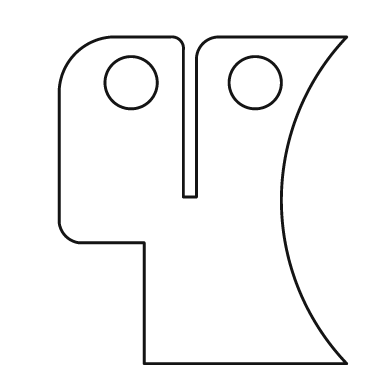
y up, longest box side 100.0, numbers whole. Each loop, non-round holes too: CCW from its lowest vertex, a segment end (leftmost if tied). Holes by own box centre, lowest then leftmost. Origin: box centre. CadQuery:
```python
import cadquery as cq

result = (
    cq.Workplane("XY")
    .moveTo(-18.0, -50.0)
    .lineTo(44.0, -50.0)
    .threePointArc((24.0, 0.0), (44.0, 50.0))
    .lineTo(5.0, 50.0)
    .threePointArc((0.0, 48.0), (-2.0, 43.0))
    .lineTo(-2.0, 1.0)
    .lineTo(-6.0, 1.0)
    .lineTo(-6.0, 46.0)
    .threePointArc((-7.0, 49.0), (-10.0, 50.0))
    .lineTo(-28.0, 50.0)
    .threePointArc((-39.0, 45.0), (-44.0, 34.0))
    .lineTo(-44.0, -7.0)
    .threePointArc((-42.0, -11.0), (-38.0, -13.0))
    .lineTo(-18.0, -13.0)
    .close()
    .moveTo(-22.0, 36.0)
    .circle(8.0)
    .moveTo(16.0, 36.0)
    .circle(8.0)
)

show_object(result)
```